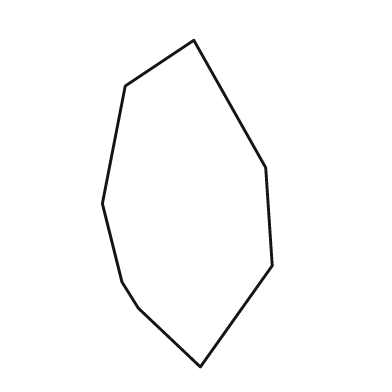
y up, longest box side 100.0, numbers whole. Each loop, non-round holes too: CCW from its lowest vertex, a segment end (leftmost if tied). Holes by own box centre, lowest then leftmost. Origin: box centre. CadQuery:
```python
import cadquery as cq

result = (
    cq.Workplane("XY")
    .moveTo(4.0, -50.0)
    .lineTo(26.0, -19.0)
    .lineTo(24.0, 11.0)
    .lineTo(2.0, 50.0)
    .lineTo(-19.0, 36.0)
    .lineTo(-26.0, 0.0)
    .lineTo(-20.0, -24.0)
    .lineTo(-15.0, -32.0)
    .close()
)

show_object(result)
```